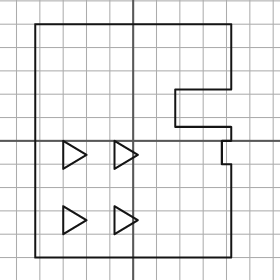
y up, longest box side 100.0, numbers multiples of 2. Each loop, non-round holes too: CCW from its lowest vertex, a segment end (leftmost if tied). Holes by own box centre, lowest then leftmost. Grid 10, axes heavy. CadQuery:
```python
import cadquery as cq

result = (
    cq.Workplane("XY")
    .moveTo(-42.0, -50.0)
    .lineTo(42.0, -50.0)
    .lineTo(42.0, -10.0)
    .lineTo(38.0, -10.0)
    .lineTo(38.0, 0.0)
    .lineTo(42.0, 0.0)
    .lineTo(42.0, 6.0)
    .lineTo(18.0, 6.0)
    .lineTo(18.0, 22.0)
    .lineTo(42.0, 22.0)
    .lineTo(42.0, 50.0)
    .lineTo(-42.0, 50.0)
    .close()
    .moveTo(-30.0, -40.0)
    .lineTo(-20.0, -34.0)
    .lineTo(-30.0, -28.0)
    .close()
    .moveTo(-8.0, -40.0)
    .lineTo(2.0, -34.0)
    .lineTo(-8.0, -28.0)
    .close()
    .moveTo(-30.0, -12.0)
    .lineTo(-20.0, -6.0)
    .lineTo(-30.0, 0.0)
    .close()
    .moveTo(-8.0, -12.0)
    .lineTo(2.0, -6.0)
    .lineTo(-8.0, 0.0)
    .close()
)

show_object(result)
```